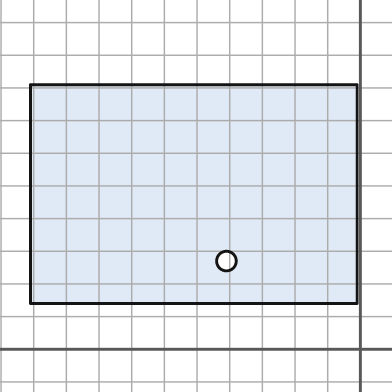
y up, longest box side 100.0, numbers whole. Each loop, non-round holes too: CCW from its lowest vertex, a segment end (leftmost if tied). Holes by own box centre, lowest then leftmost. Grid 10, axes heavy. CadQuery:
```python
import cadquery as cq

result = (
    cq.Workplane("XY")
    .moveTo(-101.0, 14.0)
    .lineTo(-1.0, 14.0)
    .lineTo(-1.0, 81.0)
    .lineTo(-101.0, 81.0)
    .close()
    .moveTo(-41.0, 27.0)
    .circle(3.0)
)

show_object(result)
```